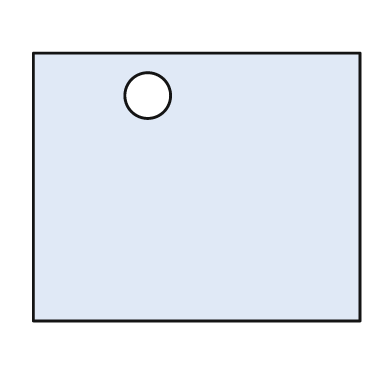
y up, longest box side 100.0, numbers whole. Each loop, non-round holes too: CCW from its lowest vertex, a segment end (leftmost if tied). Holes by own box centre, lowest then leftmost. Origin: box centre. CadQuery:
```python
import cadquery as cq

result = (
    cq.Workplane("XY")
    .moveTo(-50.0, -41.0)
    .lineTo(50.0, -41.0)
    .lineTo(50.0, 41.0)
    .lineTo(-50.0, 41.0)
    .close()
    .moveTo(-15.0, 28.0)
    .circle(7.0)
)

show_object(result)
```